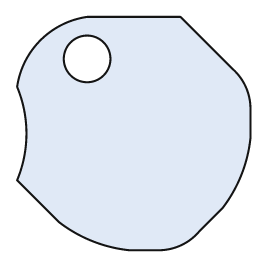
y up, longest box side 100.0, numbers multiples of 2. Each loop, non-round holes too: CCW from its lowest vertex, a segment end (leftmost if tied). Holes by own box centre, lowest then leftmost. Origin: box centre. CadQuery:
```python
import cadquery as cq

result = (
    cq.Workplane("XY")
    .moveTo(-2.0, -50.0)
    .lineTo(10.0, -50.0)
    .threePointArc((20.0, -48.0), (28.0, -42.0))
    .lineTo(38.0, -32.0)
    .threePointArc((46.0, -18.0), (50.0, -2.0))
    .lineTo(50.0, 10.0)
    .threePointArc((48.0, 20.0), (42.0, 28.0))
    .lineTo(20.0, 50.0)
    .lineTo(-20.0, 50.0)
    .threePointArc((-40.0, 40.0), (-50.0, 20.0))
    .threePointArc((-46.0, 0.0), (-50.0, -20.0))
    .lineTo(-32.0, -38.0)
    .threePointArc((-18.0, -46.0), (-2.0, -50.0))
    .close()
    .moveTo(-20.0, 32.0)
    .circle(10.0)
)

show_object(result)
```